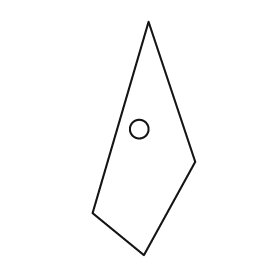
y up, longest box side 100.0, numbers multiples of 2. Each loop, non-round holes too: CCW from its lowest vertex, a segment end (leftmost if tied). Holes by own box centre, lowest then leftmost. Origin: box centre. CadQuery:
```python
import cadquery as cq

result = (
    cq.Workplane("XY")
    .moveTo(0.0, -50.0)
    .lineTo(22.0, -10.0)
    .lineTo(2.0, 50.0)
    .lineTo(-22.0, -32.0)
    .close()
    .moveTo(-2.0, 4.0)
    .circle(4.0)
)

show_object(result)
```